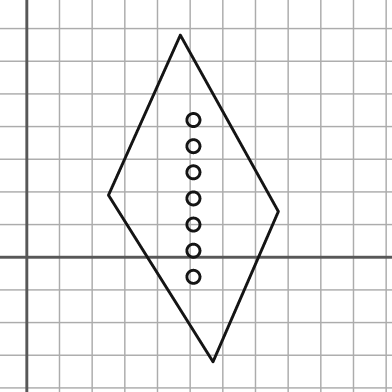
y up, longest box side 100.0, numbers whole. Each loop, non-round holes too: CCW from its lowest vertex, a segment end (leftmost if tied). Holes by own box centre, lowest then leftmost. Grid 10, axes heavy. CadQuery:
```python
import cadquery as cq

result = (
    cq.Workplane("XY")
    .moveTo(57.0, -32.0)
    .lineTo(77.0, 14.0)
    .lineTo(47.0, 68.0)
    .lineTo(25.0, 19.0)
    .close()
    .moveTo(51.0, -6.0)
    .circle(2.0)
    .moveTo(51.0, 2.0)
    .circle(2.0)
    .moveTo(51.0, 10.0)
    .circle(2.0)
    .moveTo(51.0, 18.0)
    .circle(2.0)
    .moveTo(51.0, 26.0)
    .circle(2.0)
    .moveTo(51.0, 34.0)
    .circle(2.0)
    .moveTo(51.0, 42.0)
    .circle(2.0)
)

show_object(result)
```